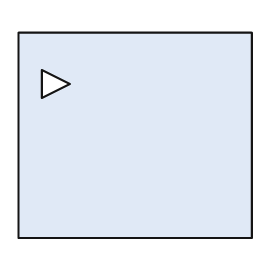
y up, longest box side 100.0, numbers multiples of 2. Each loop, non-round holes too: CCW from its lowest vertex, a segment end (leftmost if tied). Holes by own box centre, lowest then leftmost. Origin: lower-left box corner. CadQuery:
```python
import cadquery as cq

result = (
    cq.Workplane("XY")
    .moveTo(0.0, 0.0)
    .lineTo(100.0, 0.0)
    .lineTo(100.0, 88.0)
    .lineTo(0.0, 88.0)
    .close()
    .moveTo(10.0, 60.0)
    .lineTo(22.0, 66.0)
    .lineTo(10.0, 72.0)
    .close()
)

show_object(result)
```